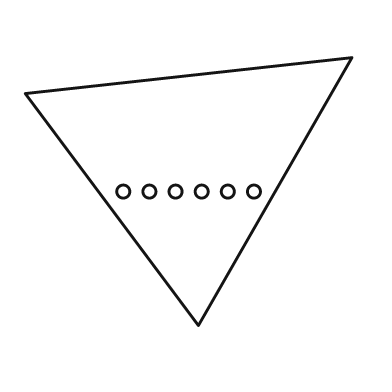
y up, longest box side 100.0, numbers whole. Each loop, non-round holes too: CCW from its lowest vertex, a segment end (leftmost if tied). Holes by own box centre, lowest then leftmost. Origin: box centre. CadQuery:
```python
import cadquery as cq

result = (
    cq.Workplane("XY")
    .moveTo(3.0, -41.0)
    .lineTo(50.0, 41.0)
    .lineTo(-50.0, 30.0)
    .close()
    .moveTo(-20.0, 0.0)
    .circle(2.0)
    .moveTo(-12.0, 0.0)
    .circle(2.0)
    .moveTo(-4.0, 0.0)
    .circle(2.0)
    .moveTo(4.0, 0.0)
    .circle(2.0)
    .moveTo(12.0, 0.0)
    .circle(2.0)
    .moveTo(20.0, 0.0)
    .circle(2.0)
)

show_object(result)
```